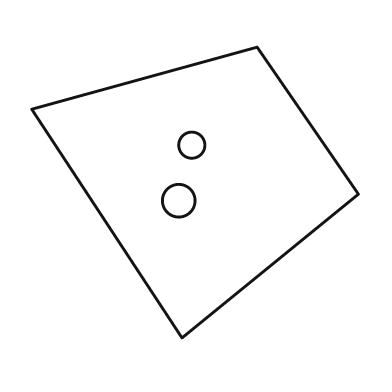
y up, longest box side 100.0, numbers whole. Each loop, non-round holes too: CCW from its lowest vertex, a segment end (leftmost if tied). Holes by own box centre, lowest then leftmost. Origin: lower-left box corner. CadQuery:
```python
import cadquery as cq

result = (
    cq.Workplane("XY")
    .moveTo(46.0, 0.0)
    .lineTo(100.0, 44.0)
    .lineTo(69.0, 89.0)
    .lineTo(0.0, 70.0)
    .close()
    .moveTo(45.0, 42.0)
    .circle(5.0)
    .moveTo(49.0, 59.0)
    .circle(4.0)
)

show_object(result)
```